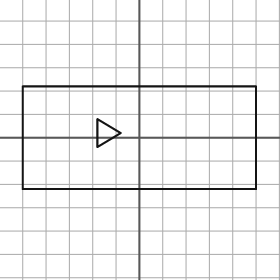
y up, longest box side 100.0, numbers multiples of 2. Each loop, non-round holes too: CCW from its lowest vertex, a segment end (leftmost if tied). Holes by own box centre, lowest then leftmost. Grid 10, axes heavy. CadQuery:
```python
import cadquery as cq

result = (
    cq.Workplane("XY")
    .moveTo(-50.0, -22.0)
    .lineTo(50.0, -22.0)
    .lineTo(50.0, 22.0)
    .lineTo(-50.0, 22.0)
    .close()
    .moveTo(-18.0, -4.0)
    .lineTo(-8.0, 2.0)
    .lineTo(-18.0, 8.0)
    .close()
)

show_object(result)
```